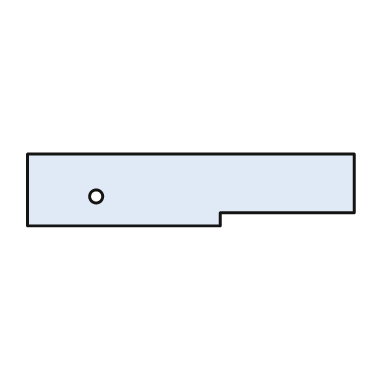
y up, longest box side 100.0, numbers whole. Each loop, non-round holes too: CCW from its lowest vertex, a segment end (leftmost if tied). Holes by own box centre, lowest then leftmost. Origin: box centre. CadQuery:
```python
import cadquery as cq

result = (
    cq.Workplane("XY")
    .moveTo(-50.0, -11.0)
    .lineTo(9.0, -11.0)
    .lineTo(9.0, -7.0)
    .lineTo(50.0, -7.0)
    .lineTo(50.0, 11.0)
    .lineTo(-50.0, 11.0)
    .close()
    .moveTo(-29.0, -2.0)
    .circle(2.0)
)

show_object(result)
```